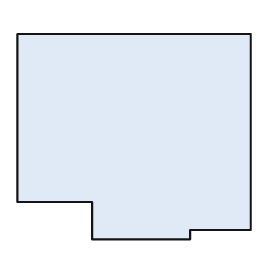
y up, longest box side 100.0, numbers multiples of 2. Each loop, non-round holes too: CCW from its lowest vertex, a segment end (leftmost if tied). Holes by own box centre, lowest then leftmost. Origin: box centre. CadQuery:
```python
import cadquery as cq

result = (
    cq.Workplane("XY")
    .moveTo(-18.0, -44.0)
    .lineTo(24.0, -44.0)
    .lineTo(24.0, -40.0)
    .lineTo(50.0, -40.0)
    .lineTo(50.0, 44.0)
    .lineTo(-50.0, 44.0)
    .lineTo(-50.0, -28.0)
    .lineTo(-18.0, -28.0)
    .close()
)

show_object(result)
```